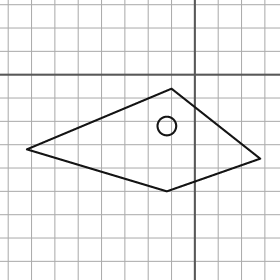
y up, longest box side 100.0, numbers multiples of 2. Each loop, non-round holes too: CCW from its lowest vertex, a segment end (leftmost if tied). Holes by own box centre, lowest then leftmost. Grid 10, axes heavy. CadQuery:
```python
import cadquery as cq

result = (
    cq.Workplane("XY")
    .moveTo(-12.0, -50.0)
    .lineTo(28.0, -36.0)
    .lineTo(-10.0, -6.0)
    .lineTo(-72.0, -32.0)
    .close()
    .moveTo(-12.0, -22.0)
    .circle(4.0)
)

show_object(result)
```